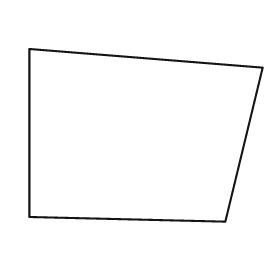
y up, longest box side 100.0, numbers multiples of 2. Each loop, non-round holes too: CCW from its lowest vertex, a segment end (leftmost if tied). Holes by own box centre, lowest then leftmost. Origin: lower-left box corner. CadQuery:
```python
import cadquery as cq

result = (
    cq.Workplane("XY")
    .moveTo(84.0, 0.0)
    .lineTo(100.0, 66.0)
    .lineTo(0.0, 74.0)
    .lineTo(0.0, 2.0)
    .close()
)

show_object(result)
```